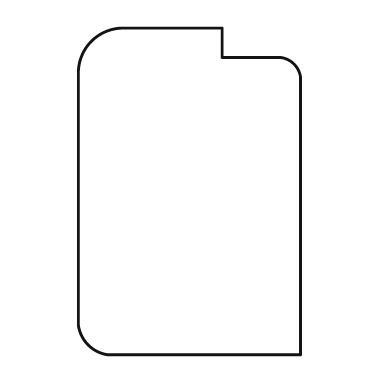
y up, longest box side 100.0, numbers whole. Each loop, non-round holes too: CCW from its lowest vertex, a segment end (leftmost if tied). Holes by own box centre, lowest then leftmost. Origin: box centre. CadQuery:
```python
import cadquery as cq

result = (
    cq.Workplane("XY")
    .moveTo(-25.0, -50.0)
    .lineTo(34.0, -50.0)
    .lineTo(34.0, 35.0)
    .threePointArc((32.0, 39.0), (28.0, 41.0))
    .lineTo(10.0, 41.0)
    .lineTo(10.0, 50.0)
    .lineTo(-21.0, 50.0)
    .threePointArc((-30.0, 46.0), (-34.0, 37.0))
    .lineTo(-34.0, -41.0)
    .threePointArc((-31.0, -47.0), (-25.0, -50.0))
    .close()
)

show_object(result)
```